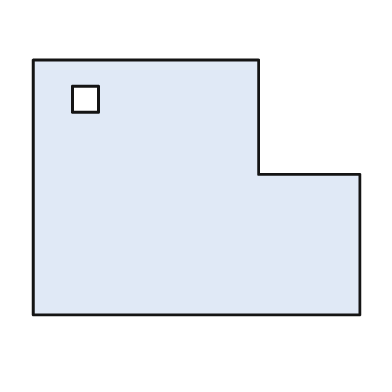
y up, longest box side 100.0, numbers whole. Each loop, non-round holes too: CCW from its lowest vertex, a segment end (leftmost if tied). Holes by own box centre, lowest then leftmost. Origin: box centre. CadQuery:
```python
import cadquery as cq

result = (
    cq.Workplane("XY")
    .moveTo(-50.0, -39.0)
    .lineTo(50.0, -39.0)
    .lineTo(50.0, 4.0)
    .lineTo(19.0, 4.0)
    .lineTo(19.0, 39.0)
    .lineTo(-50.0, 39.0)
    .close()
    .moveTo(-38.0, 23.0)
    .lineTo(-30.0, 23.0)
    .lineTo(-30.0, 31.0)
    .lineTo(-38.0, 31.0)
    .close()
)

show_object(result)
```